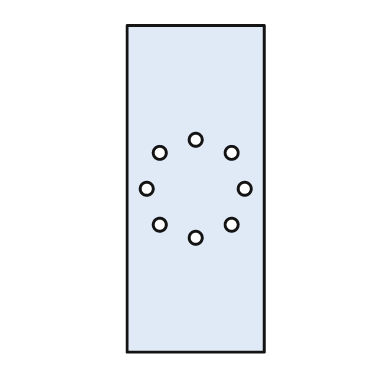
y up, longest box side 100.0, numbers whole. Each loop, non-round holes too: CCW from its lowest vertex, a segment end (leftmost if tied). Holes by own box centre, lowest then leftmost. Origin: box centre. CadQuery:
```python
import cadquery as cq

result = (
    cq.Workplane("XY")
    .moveTo(-21.0, -50.0)
    .lineTo(21.0, -50.0)
    .lineTo(21.0, 50.0)
    .lineTo(-21.0, 50.0)
    .close()
    .moveTo(0.0, -15.0)
    .circle(2.0)
    .moveTo(-11.0, -11.0)
    .circle(2.0)
    .moveTo(11.0, -11.0)
    .circle(2.0)
    .moveTo(-15.0, 0.0)
    .circle(2.0)
    .moveTo(15.0, 0.0)
    .circle(2.0)
    .moveTo(-11.0, 11.0)
    .circle(2.0)
    .moveTo(11.0, 11.0)
    .circle(2.0)
    .moveTo(0.0, 15.0)
    .circle(2.0)
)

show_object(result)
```